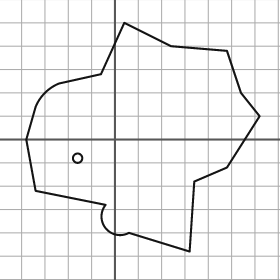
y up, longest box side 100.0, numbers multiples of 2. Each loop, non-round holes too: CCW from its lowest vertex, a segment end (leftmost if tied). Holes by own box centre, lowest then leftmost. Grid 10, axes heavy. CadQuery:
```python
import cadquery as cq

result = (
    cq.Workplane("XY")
    .moveTo(32.0, -48.0)
    .lineTo(34.0, -18.0)
    .lineTo(48.0, -12.0)
    .lineTo(62.0, 10.0)
    .lineTo(54.0, 20.0)
    .lineTo(48.0, 38.0)
    .lineTo(24.0, 40.0)
    .lineTo(4.0, 50.0)
    .lineTo(-6.0, 28.0)
    .lineTo(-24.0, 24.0)
    .threePointArc((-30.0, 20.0), (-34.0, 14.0))
    .lineTo(-38.0, 0.0)
    .lineTo(-34.0, -22.0)
    .lineTo(-4.0, -28.0)
    .threePointArc((-4.0, -38.0), (6.0, -40.0))
    .close()
    .moveTo(-16.0, -8.0)
    .circle(2.0)
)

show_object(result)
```